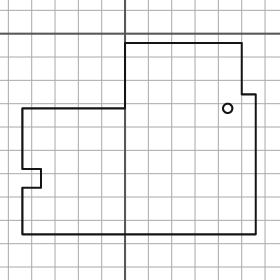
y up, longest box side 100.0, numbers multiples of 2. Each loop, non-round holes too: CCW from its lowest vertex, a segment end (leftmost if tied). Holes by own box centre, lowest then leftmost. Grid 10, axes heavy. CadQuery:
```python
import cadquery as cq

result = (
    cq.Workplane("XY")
    .moveTo(-44.0, -86.0)
    .lineTo(56.0, -86.0)
    .lineTo(56.0, -26.0)
    .lineTo(50.0, -26.0)
    .lineTo(50.0, -4.0)
    .lineTo(0.0, -4.0)
    .lineTo(0.0, -32.0)
    .lineTo(-44.0, -32.0)
    .lineTo(-44.0, -58.0)
    .lineTo(-36.0, -58.0)
    .lineTo(-36.0, -66.0)
    .lineTo(-44.0, -66.0)
    .close()
    .moveTo(44.0, -32.0)
    .circle(2.0)
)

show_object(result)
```